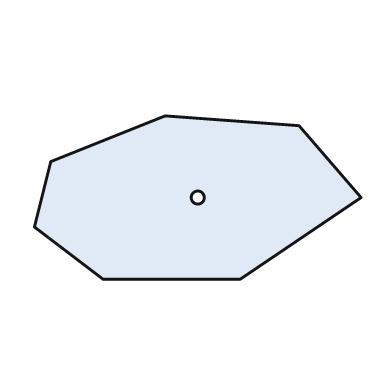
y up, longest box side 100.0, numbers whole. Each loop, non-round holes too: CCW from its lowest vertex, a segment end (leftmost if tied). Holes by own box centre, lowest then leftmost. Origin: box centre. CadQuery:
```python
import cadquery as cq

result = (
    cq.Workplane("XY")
    .moveTo(-29.0, -25.0)
    .lineTo(13.0, -25.0)
    .lineTo(50.0, 0.0)
    .lineTo(31.0, 22.0)
    .lineTo(-10.0, 25.0)
    .lineTo(-45.0, 11.0)
    .lineTo(-50.0, -9.0)
    .close()
    .moveTo(0.0, 0.0)
    .circle(2.0)
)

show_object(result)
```